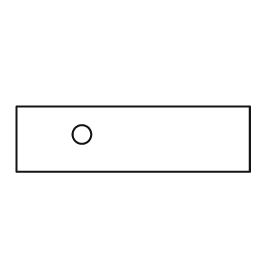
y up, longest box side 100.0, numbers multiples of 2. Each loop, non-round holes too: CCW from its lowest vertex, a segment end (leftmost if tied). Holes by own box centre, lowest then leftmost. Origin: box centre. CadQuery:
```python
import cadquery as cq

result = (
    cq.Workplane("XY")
    .moveTo(-50.0, -14.0)
    .lineTo(50.0, -14.0)
    .lineTo(50.0, 14.0)
    .lineTo(-50.0, 14.0)
    .close()
    .moveTo(-22.0, 2.0)
    .circle(4.0)
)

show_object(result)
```